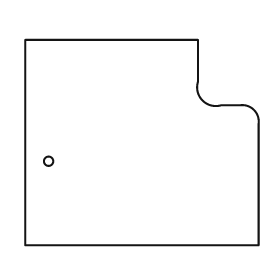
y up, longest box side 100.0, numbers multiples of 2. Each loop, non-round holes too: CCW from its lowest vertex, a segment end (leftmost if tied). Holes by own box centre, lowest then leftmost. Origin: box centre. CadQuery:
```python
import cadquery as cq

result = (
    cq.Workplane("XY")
    .moveTo(-50.0, -44.0)
    .lineTo(50.0, -44.0)
    .lineTo(50.0, 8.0)
    .threePointArc((48.0, 14.0), (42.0, 16.0))
    .lineTo(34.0, 16.0)
    .threePointArc((26.0, 18.0), (24.0, 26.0))
    .lineTo(24.0, 44.0)
    .lineTo(-50.0, 44.0)
    .close()
    .moveTo(-40.0, -8.0)
    .circle(2.0)
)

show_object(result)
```